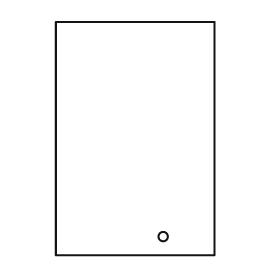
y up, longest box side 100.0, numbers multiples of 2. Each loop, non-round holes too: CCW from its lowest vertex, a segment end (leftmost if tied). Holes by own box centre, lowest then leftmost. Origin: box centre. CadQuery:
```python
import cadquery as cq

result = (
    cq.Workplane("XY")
    .moveTo(-34.0, -50.0)
    .lineTo(34.0, -50.0)
    .lineTo(34.0, 50.0)
    .lineTo(-34.0, 50.0)
    .close()
    .moveTo(12.0, -42.0)
    .circle(2.0)
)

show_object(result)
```